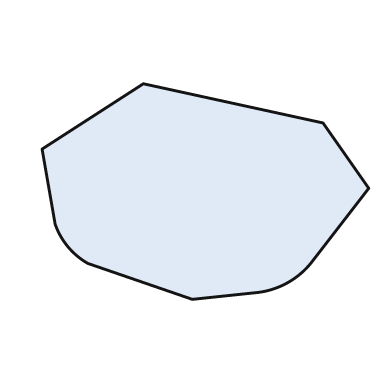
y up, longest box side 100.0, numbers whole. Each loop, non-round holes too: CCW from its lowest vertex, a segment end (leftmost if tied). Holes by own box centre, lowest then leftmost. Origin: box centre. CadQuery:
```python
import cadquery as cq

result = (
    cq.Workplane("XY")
    .moveTo(-4.0, -33.0)
    .lineTo(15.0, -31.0)
    .threePointArc((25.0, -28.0), (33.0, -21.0))
    .lineTo(50.0, 1.0)
    .lineTo(36.0, 21.0)
    .lineTo(-19.0, 33.0)
    .lineTo(-50.0, 13.0)
    .lineTo(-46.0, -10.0)
    .threePointArc((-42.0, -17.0), (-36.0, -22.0))
    .close()
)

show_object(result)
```